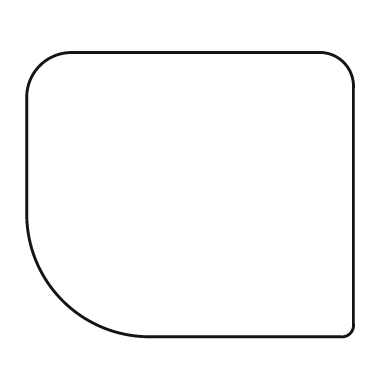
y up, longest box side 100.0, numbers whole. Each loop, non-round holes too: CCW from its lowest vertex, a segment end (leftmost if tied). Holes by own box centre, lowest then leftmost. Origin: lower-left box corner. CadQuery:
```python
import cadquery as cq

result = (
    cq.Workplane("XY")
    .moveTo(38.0, 0.0)
    .lineTo(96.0, 0.0)
    .threePointArc((99.0, 1.0), (100.0, 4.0))
    .lineTo(100.0, 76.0)
    .threePointArc((97.0, 84.0), (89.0, 87.0))
    .lineTo(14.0, 87.0)
    .threePointArc((4.0, 83.0), (0.0, 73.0))
    .lineTo(0.0, 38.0)
    .threePointArc((11.0, 11.0), (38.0, 0.0))
    .close()
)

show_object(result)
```